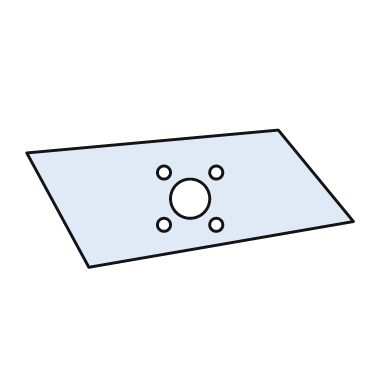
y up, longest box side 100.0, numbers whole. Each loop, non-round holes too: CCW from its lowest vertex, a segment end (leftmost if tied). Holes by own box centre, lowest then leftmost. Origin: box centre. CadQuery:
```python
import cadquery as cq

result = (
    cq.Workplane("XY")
    .moveTo(-31.0, -21.0)
    .lineTo(50.0, -7.0)
    .lineTo(27.0, 21.0)
    .lineTo(-50.0, 14.0)
    .close()
    .moveTo(-8.0, -8.0)
    .circle(2.0)
    .moveTo(8.0, -8.0)
    .circle(2.0)
    .moveTo(0.0, 0.0)
    .circle(6.0)
    .moveTo(-8.0, 8.0)
    .circle(2.0)
    .moveTo(8.0, 8.0)
    .circle(2.0)
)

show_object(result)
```